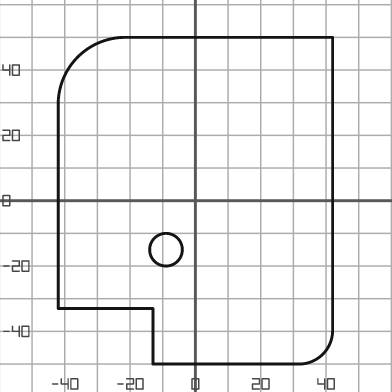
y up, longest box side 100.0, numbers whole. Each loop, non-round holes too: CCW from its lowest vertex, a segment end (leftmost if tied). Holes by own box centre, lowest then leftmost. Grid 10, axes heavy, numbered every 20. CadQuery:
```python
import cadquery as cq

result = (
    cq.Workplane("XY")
    .moveTo(-13.0, -50.0)
    .lineTo(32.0, -50.0)
    .threePointArc((39.0, -47.0), (42.0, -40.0))
    .lineTo(42.0, 50.0)
    .lineTo(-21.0, 50.0)
    .threePointArc((-36.0, 44.0), (-42.0, 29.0))
    .lineTo(-42.0, -33.0)
    .lineTo(-13.0, -33.0)
    .close()
    .moveTo(-9.0, -15.0)
    .circle(5.0)
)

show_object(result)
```